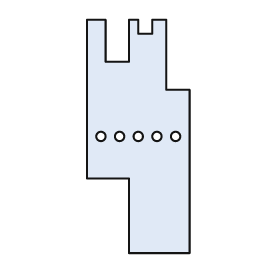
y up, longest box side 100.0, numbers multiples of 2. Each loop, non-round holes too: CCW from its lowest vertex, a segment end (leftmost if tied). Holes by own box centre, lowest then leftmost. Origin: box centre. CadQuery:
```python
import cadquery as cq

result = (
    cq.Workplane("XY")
    .moveTo(-4.0, -50.0)
    .lineTo(22.0, -50.0)
    .lineTo(22.0, 20.0)
    .lineTo(12.0, 20.0)
    .lineTo(12.0, 50.0)
    .lineTo(6.0, 50.0)
    .lineTo(6.0, 44.0)
    .lineTo(0.0, 44.0)
    .lineTo(0.0, 50.0)
    .lineTo(-4.0, 50.0)
    .lineTo(-4.0, 32.0)
    .lineTo(-14.0, 32.0)
    .lineTo(-14.0, 50.0)
    .lineTo(-22.0, 50.0)
    .lineTo(-22.0, -18.0)
    .lineTo(-4.0, -18.0)
    .close()
    .moveTo(-16.0, 0.0)
    .circle(2.0)
    .moveTo(-8.0, 0.0)
    .circle(2.0)
    .moveTo(0.0, 0.0)
    .circle(2.0)
    .moveTo(8.0, 0.0)
    .circle(2.0)
    .moveTo(16.0, 0.0)
    .circle(2.0)
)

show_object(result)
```